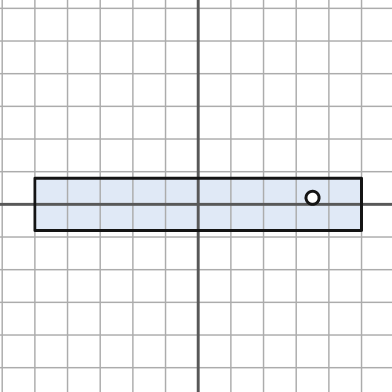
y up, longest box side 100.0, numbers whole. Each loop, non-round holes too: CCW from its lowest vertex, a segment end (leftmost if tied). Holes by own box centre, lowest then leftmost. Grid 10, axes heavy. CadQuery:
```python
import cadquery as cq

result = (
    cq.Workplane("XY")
    .moveTo(-50.0, -8.0)
    .lineTo(50.0, -8.0)
    .lineTo(50.0, 8.0)
    .lineTo(-50.0, 8.0)
    .close()
    .moveTo(35.0, 2.0)
    .circle(2.0)
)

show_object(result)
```